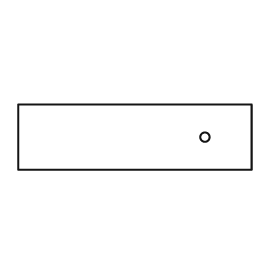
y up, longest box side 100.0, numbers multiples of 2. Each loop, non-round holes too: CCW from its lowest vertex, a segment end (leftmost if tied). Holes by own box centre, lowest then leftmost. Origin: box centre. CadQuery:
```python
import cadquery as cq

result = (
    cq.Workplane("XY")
    .moveTo(-50.0, -14.0)
    .lineTo(50.0, -14.0)
    .lineTo(50.0, 14.0)
    .lineTo(-50.0, 14.0)
    .close()
    .moveTo(30.0, 0.0)
    .circle(2.0)
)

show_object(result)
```